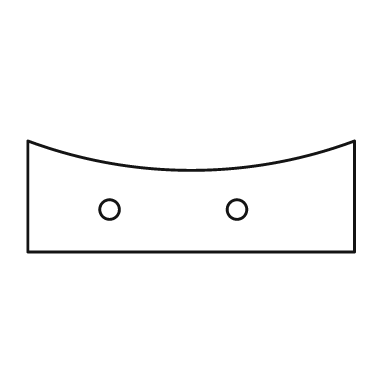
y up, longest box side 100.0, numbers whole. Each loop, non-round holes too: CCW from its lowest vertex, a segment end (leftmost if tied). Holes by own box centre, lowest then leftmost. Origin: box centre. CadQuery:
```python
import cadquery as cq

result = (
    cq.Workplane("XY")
    .moveTo(-50.0, -17.0)
    .lineTo(50.0, -17.0)
    .lineTo(50.0, 17.0)
    .threePointArc((0.0, 8.0), (-50.0, 17.0))
    .close()
    .moveTo(-25.0, -4.0)
    .circle(3.0)
    .moveTo(14.0, -4.0)
    .circle(3.0)
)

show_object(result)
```